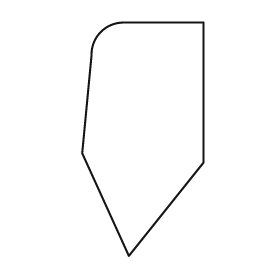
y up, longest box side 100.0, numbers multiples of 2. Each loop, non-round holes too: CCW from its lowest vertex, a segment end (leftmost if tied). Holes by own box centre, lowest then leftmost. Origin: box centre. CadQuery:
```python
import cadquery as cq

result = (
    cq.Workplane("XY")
    .moveTo(-6.0, -50.0)
    .lineTo(26.0, -10.0)
    .lineTo(26.0, 50.0)
    .lineTo(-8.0, 50.0)
    .threePointArc((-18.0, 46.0), (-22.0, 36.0))
    .lineTo(-26.0, -6.0)
    .close()
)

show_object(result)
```